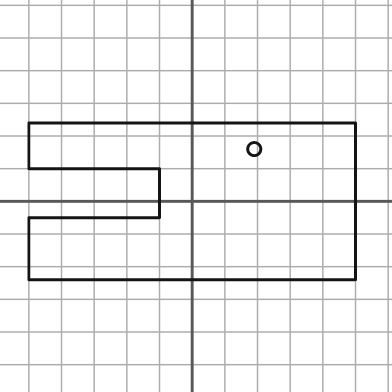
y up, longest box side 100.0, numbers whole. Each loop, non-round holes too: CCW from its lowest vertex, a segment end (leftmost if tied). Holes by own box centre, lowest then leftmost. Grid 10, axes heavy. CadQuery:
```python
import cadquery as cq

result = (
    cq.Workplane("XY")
    .moveTo(-50.0, -24.0)
    .lineTo(50.0, -24.0)
    .lineTo(50.0, 24.0)
    .lineTo(-50.0, 24.0)
    .lineTo(-50.0, 10.0)
    .lineTo(-10.0, 10.0)
    .lineTo(-10.0, -5.0)
    .lineTo(-50.0, -5.0)
    .close()
    .moveTo(19.0, 16.0)
    .circle(2.0)
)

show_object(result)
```